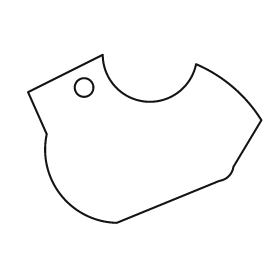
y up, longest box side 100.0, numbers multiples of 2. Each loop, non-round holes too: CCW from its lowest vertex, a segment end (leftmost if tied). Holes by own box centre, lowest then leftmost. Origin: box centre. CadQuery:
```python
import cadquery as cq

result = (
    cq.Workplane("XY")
    .moveTo(-12.0, -36.0)
    .lineTo(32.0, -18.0)
    .threePointArc((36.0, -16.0), (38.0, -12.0))
    .lineTo(50.0, 8.0)
    .threePointArc((38.0, 22.0), (22.0, 32.0))
    .threePointArc((0.0, 16.0), (-18.0, 36.0))
    .lineTo(-50.0, 20.0)
    .lineTo(-42.0, 2.0)
    .threePointArc((-36.0, -24.0), (-12.0, -36.0))
    .close()
    .moveTo(-26.0, 22.0)
    .circle(4.0)
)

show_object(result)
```